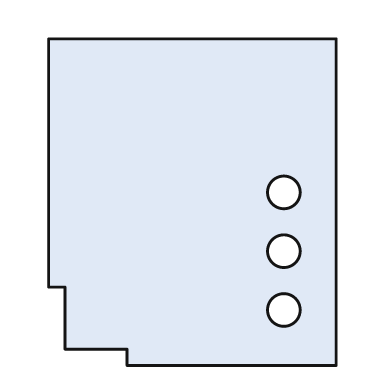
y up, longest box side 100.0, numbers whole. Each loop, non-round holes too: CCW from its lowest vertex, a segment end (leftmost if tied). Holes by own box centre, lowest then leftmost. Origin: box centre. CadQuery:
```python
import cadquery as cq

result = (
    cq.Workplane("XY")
    .moveTo(-20.0, -50.0)
    .lineTo(44.0, -50.0)
    .lineTo(44.0, 50.0)
    .lineTo(-44.0, 50.0)
    .lineTo(-44.0, -26.0)
    .lineTo(-39.0, -26.0)
    .lineTo(-39.0, -45.0)
    .lineTo(-20.0, -45.0)
    .close()
    .moveTo(28.0, -33.0)
    .circle(5.0)
    .moveTo(28.0, -15.0)
    .circle(5.0)
    .moveTo(28.0, 3.0)
    .circle(5.0)
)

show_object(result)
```